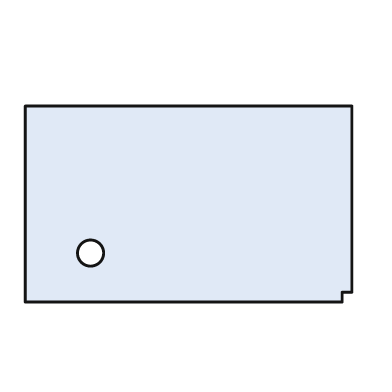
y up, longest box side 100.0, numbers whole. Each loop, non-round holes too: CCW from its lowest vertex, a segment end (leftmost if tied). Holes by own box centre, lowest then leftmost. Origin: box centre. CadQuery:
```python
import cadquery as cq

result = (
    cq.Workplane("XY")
    .moveTo(-50.0, -30.0)
    .lineTo(47.0, -30.0)
    .lineTo(47.0, -27.0)
    .lineTo(50.0, -27.0)
    .lineTo(50.0, 30.0)
    .lineTo(-50.0, 30.0)
    .close()
    .moveTo(-30.0, -15.0)
    .circle(4.0)
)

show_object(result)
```